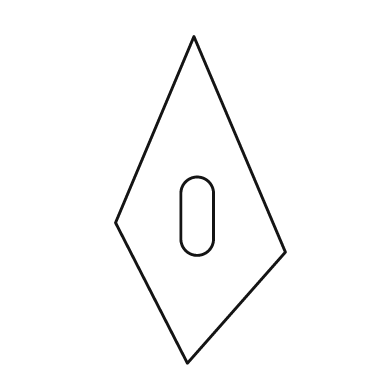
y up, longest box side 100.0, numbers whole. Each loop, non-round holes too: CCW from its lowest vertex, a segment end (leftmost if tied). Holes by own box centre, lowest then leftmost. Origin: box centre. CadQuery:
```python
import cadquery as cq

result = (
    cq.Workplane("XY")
    .moveTo(-4.0, -50.0)
    .lineTo(26.0, -16.0)
    .lineTo(-2.0, 50.0)
    .lineTo(-26.0, -7.0)
    .close()
    .moveTo(-6.0, -12.0)
    .threePointArc((-1.0, -17.0), (4.0, -12.0))
    .lineTo(4.0, 2.0)
    .threePointArc((-1.0, 7.0), (-6.0, 2.0))
    .close()
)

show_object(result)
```